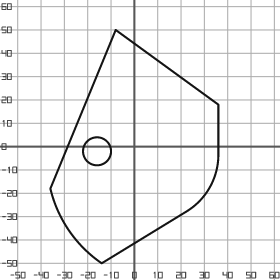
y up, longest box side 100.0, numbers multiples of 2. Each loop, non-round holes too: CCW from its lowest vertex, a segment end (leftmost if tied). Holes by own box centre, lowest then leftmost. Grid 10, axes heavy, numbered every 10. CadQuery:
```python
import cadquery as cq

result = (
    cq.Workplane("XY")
    .moveTo(-14.0, -50.0)
    .lineTo(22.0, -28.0)
    .threePointArc((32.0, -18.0), (36.0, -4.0))
    .lineTo(36.0, 18.0)
    .lineTo(-8.0, 50.0)
    .lineTo(-36.0, -18.0)
    .threePointArc((-28.0, -36.0), (-14.0, -50.0))
    .close()
    .moveTo(-16.0, -2.0)
    .circle(6.0)
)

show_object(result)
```